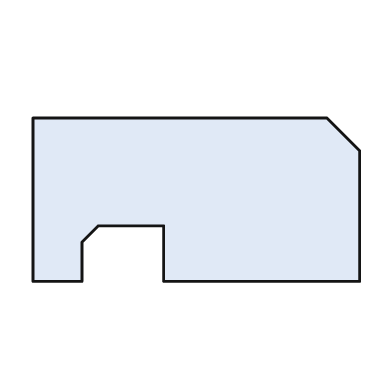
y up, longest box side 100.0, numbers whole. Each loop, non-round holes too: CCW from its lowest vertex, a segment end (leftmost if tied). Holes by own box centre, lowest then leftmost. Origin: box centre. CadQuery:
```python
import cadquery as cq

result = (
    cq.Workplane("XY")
    .moveTo(-50.0, -25.0)
    .lineTo(-35.0, -25.0)
    .lineTo(-35.0, -13.0)
    .lineTo(-30.0, -8.0)
    .lineTo(-10.0, -8.0)
    .lineTo(-10.0, -25.0)
    .lineTo(50.0, -25.0)
    .lineTo(50.0, 15.0)
    .lineTo(40.0, 25.0)
    .lineTo(-50.0, 25.0)
    .close()
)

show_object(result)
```